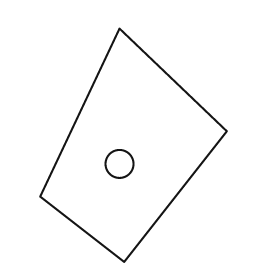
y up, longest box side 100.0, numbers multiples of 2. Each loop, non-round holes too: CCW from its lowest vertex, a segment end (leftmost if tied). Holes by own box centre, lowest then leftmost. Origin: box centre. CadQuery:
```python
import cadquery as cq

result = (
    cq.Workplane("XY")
    .moveTo(-4.0, -50.0)
    .lineTo(40.0, 6.0)
    .lineTo(-6.0, 50.0)
    .lineTo(-40.0, -22.0)
    .close()
    .moveTo(-6.0, -8.0)
    .circle(6.0)
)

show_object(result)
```